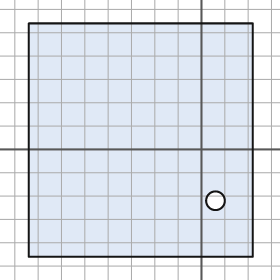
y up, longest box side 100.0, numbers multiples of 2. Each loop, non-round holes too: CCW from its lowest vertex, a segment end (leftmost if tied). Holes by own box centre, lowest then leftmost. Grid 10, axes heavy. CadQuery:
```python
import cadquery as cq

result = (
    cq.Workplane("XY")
    .moveTo(-74.0, -46.0)
    .lineTo(22.0, -46.0)
    .lineTo(22.0, 54.0)
    .lineTo(-74.0, 54.0)
    .close()
    .moveTo(6.0, -22.0)
    .circle(4.0)
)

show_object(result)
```